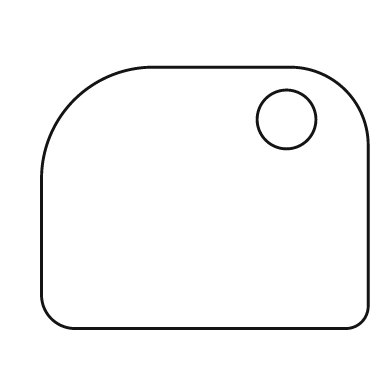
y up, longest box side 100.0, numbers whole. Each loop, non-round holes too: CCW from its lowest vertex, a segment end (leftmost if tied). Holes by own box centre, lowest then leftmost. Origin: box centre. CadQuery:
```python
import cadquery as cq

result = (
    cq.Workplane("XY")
    .moveTo(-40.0, -40.0)
    .lineTo(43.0, -40.0)
    .threePointArc((48.0, -38.0), (50.0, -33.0))
    .lineTo(50.0, 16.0)
    .threePointArc((43.0, 33.0), (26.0, 40.0))
    .lineTo(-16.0, 40.0)
    .threePointArc((-40.0, 30.0), (-50.0, 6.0))
    .lineTo(-50.0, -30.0)
    .threePointArc((-47.0, -37.0), (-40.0, -40.0))
    .close()
    .moveTo(25.0, 24.0)
    .circle(9.0)
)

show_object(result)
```